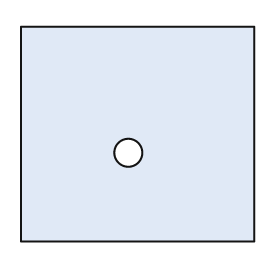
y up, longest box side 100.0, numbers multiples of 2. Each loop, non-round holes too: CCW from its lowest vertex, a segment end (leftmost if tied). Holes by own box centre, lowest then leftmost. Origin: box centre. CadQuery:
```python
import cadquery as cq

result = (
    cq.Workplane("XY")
    .moveTo(-50.0, -46.0)
    .lineTo(50.0, -46.0)
    .lineTo(50.0, 46.0)
    .lineTo(-50.0, 46.0)
    .close()
    .moveTo(-4.0, -8.0)
    .circle(6.0)
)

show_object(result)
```